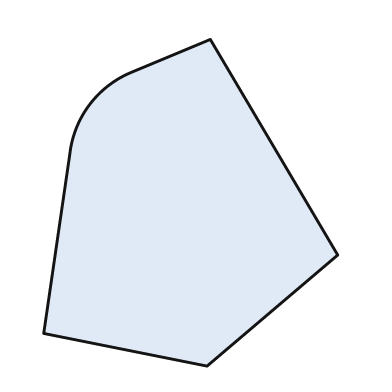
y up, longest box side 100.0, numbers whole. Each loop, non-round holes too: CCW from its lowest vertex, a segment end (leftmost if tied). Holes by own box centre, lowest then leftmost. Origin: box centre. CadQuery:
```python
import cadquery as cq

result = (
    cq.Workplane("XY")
    .moveTo(5.0, -50.0)
    .lineTo(45.0, -16.0)
    .lineTo(6.0, 50.0)
    .lineTo(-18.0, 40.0)
    .threePointArc((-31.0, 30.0), (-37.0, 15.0))
    .lineTo(-45.0, -40.0)
    .close()
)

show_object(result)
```